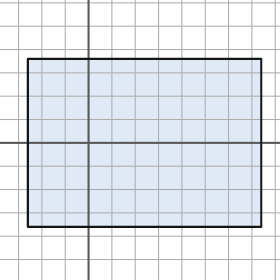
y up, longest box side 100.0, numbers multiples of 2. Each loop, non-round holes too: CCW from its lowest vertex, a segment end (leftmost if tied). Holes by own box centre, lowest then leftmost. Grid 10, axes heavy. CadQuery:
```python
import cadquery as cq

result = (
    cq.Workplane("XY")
    .moveTo(-26.0, -36.0)
    .lineTo(74.0, -36.0)
    .lineTo(74.0, 36.0)
    .lineTo(-26.0, 36.0)
    .close()
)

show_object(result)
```